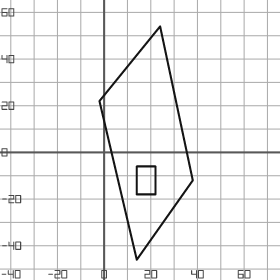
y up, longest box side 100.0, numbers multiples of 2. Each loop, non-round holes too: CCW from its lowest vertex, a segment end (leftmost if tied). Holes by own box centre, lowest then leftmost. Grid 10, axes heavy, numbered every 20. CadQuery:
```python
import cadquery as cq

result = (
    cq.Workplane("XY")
    .moveTo(14.0, -46.0)
    .lineTo(38.0, -12.0)
    .lineTo(24.0, 54.0)
    .lineTo(-2.0, 22.0)
    .close()
    .moveTo(14.0, -18.0)
    .lineTo(22.0, -18.0)
    .lineTo(22.0, -6.0)
    .lineTo(14.0, -6.0)
    .close()
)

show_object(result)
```